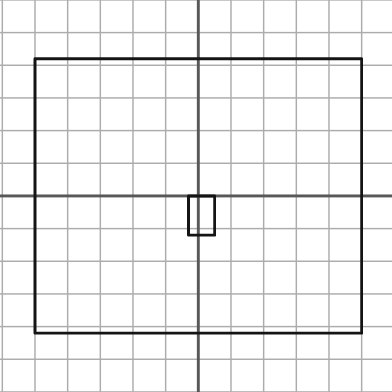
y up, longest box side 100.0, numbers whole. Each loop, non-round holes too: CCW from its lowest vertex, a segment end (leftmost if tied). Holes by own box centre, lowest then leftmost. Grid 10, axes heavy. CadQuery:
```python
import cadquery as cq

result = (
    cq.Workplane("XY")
    .moveTo(-50.0, -42.0)
    .lineTo(50.0, -42.0)
    .lineTo(50.0, 42.0)
    .lineTo(-50.0, 42.0)
    .close()
    .moveTo(-3.0, -12.0)
    .lineTo(5.0, -12.0)
    .lineTo(5.0, 0.0)
    .lineTo(-3.0, 0.0)
    .close()
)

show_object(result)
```